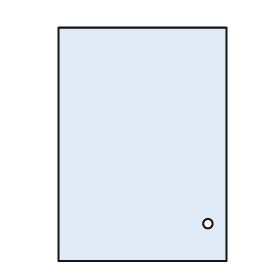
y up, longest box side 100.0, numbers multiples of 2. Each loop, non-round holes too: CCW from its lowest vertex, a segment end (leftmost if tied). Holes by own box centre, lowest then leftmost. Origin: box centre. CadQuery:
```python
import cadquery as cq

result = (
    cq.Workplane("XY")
    .moveTo(-36.0, -50.0)
    .lineTo(36.0, -50.0)
    .lineTo(36.0, 50.0)
    .lineTo(-36.0, 50.0)
    .close()
    .moveTo(28.0, -34.0)
    .circle(2.0)
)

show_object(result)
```